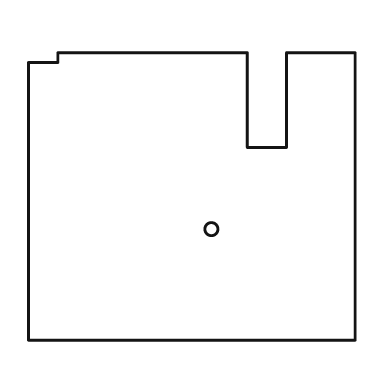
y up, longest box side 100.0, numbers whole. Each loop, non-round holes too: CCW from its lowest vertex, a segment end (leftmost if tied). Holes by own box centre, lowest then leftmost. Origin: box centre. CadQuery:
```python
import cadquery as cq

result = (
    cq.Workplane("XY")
    .moveTo(-50.0, -44.0)
    .lineTo(50.0, -44.0)
    .lineTo(50.0, 44.0)
    .lineTo(29.0, 44.0)
    .lineTo(29.0, 15.0)
    .lineTo(17.0, 15.0)
    .lineTo(17.0, 44.0)
    .lineTo(-41.0, 44.0)
    .lineTo(-41.0, 41.0)
    .lineTo(-50.0, 41.0)
    .close()
    .moveTo(6.0, -10.0)
    .circle(2.0)
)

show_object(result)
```